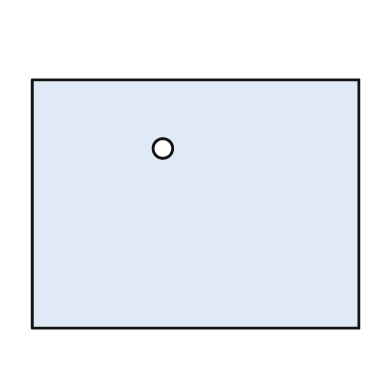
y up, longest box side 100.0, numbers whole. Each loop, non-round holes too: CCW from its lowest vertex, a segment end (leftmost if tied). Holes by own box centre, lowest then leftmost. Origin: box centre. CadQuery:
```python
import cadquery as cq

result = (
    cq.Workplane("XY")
    .moveTo(-50.0, -38.0)
    .lineTo(50.0, -38.0)
    .lineTo(50.0, 38.0)
    .lineTo(-50.0, 38.0)
    .close()
    .moveTo(-10.0, 17.0)
    .circle(3.0)
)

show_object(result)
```